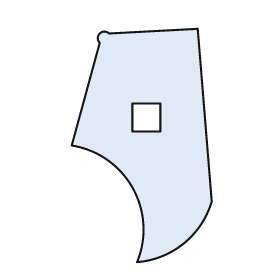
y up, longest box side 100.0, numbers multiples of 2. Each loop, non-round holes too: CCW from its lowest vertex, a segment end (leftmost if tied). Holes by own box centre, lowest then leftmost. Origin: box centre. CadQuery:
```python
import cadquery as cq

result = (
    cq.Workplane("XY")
    .moveTo(-2.0, -50.0)
    .threePointArc((18.0, -42.0), (30.0, -24.0))
    .lineTo(24.0, 50.0)
    .lineTo(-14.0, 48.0)
    .threePointArc((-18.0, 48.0), (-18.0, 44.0))
    .lineTo(-30.0, 0.0)
    .threePointArc((-4.0, -18.0), (-2.0, -50.0))
    .close()
    .moveTo(-4.0, 6.0)
    .lineTo(8.0, 6.0)
    .lineTo(8.0, 18.0)
    .lineTo(-4.0, 18.0)
    .close()
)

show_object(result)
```